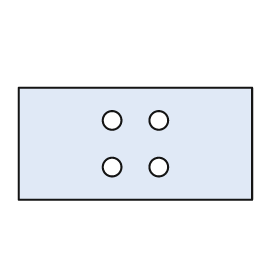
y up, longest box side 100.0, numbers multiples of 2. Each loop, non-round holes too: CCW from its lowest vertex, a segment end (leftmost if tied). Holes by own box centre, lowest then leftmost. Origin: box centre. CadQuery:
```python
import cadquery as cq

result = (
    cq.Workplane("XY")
    .moveTo(-50.0, -24.0)
    .lineTo(50.0, -24.0)
    .lineTo(50.0, 24.0)
    .lineTo(-50.0, 24.0)
    .close()
    .moveTo(-10.0, -10.0)
    .circle(4.0)
    .moveTo(10.0, -10.0)
    .circle(4.0)
    .moveTo(-10.0, 10.0)
    .circle(4.0)
    .moveTo(10.0, 10.0)
    .circle(4.0)
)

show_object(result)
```